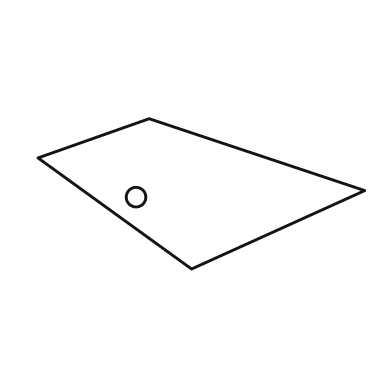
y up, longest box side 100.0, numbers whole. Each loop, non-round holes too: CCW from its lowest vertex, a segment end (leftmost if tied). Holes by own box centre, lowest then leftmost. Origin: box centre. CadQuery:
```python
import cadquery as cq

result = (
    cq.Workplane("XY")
    .moveTo(-3.0, -23.0)
    .lineTo(50.0, 1.0)
    .lineTo(-16.0, 23.0)
    .lineTo(-50.0, 11.0)
    .close()
    .moveTo(-20.0, -1.0)
    .circle(3.0)
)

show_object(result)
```